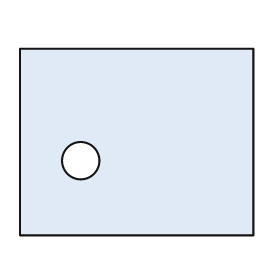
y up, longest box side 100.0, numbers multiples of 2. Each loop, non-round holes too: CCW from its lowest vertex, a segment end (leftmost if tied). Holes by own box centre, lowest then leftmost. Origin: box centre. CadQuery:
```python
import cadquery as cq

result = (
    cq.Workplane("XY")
    .moveTo(-50.0, -40.0)
    .lineTo(50.0, -40.0)
    .lineTo(50.0, 40.0)
    .lineTo(-50.0, 40.0)
    .close()
    .moveTo(-24.0, -8.0)
    .circle(8.0)
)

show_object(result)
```